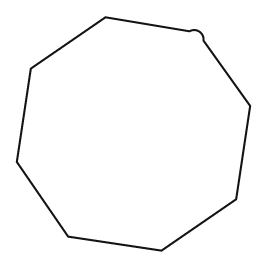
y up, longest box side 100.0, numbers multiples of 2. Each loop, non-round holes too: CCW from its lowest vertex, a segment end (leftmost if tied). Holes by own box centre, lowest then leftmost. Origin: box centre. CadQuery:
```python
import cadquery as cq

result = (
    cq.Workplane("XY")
    .moveTo(12.0, -50.0)
    .lineTo(44.0, -28.0)
    .lineTo(50.0, 12.0)
    .lineTo(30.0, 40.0)
    .threePointArc((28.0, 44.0), (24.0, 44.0))
    .lineTo(-12.0, 50.0)
    .lineTo(-44.0, 28.0)
    .lineTo(-50.0, -12.0)
    .lineTo(-28.0, -44.0)
    .close()
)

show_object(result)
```